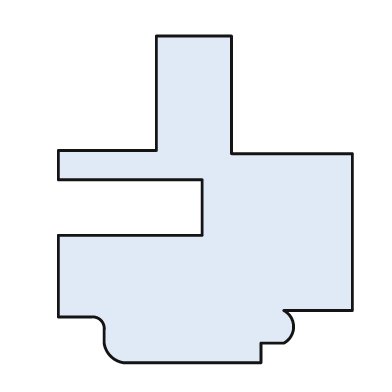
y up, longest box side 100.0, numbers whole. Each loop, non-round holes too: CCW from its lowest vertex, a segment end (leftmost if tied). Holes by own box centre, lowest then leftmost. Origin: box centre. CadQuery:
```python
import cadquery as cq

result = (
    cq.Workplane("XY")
    .moveTo(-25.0, -50.0)
    .lineTo(17.0, -50.0)
    .lineTo(17.0, -44.0)
    .lineTo(24.0, -44.0)
    .threePointArc((27.0, -39.0), (24.0, -34.0))
    .lineTo(45.0, -34.0)
    .lineTo(45.0, 14.0)
    .lineTo(8.0, 14.0)
    .lineTo(8.0, 50.0)
    .lineTo(-15.0, 50.0)
    .lineTo(-15.0, 15.0)
    .lineTo(-45.0, 15.0)
    .lineTo(-45.0, 6.0)
    .lineTo(-1.0, 6.0)
    .lineTo(-1.0, -11.0)
    .lineTo(-45.0, -11.0)
    .lineTo(-45.0, -36.0)
    .lineTo(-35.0, -36.0)
    .threePointArc((-32.0, -37.0), (-31.0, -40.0))
    .lineTo(-31.0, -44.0)
    .threePointArc((-29.0, -48.0), (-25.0, -50.0))
    .close()
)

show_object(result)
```